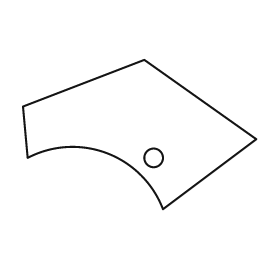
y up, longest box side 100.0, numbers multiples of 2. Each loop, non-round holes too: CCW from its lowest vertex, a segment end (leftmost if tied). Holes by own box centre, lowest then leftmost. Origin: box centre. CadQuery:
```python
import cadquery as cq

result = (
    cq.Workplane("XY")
    .moveTo(10.0, -32.0)
    .lineTo(50.0, -2.0)
    .lineTo(2.0, 32.0)
    .lineTo(-50.0, 12.0)
    .lineTo(-48.0, -10.0)
    .threePointArc((-14.0, -8.0), (10.0, -32.0))
    .close()
    .moveTo(6.0, -10.0)
    .circle(4.0)
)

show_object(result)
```